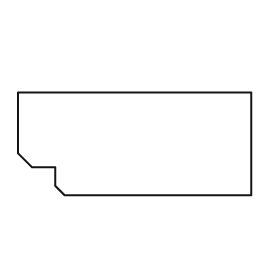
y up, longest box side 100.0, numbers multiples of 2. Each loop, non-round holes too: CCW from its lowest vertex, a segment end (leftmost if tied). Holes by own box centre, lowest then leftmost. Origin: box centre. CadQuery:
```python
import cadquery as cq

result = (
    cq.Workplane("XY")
    .moveTo(-30.0, -22.0)
    .lineTo(50.0, -22.0)
    .lineTo(50.0, 22.0)
    .lineTo(-50.0, 22.0)
    .lineTo(-50.0, -4.0)
    .lineTo(-44.0, -10.0)
    .lineTo(-34.0, -10.0)
    .lineTo(-34.0, -18.0)
    .close()
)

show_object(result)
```